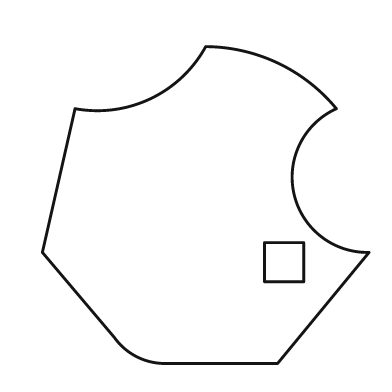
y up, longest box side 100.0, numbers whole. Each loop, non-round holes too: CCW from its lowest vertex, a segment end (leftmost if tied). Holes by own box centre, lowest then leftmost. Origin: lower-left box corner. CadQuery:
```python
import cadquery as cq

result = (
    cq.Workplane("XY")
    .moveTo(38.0, 0.0)
    .lineTo(72.0, 0.0)
    .lineTo(100.0, 34.0)
    .threePointArc((77.0, 52.0), (90.0, 78.0))
    .threePointArc((72.0, 92.0), (50.0, 97.0))
    .threePointArc((33.0, 81.0), (10.0, 78.0))
    .lineTo(0.0, 34.0)
    .lineTo(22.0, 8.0)
    .threePointArc((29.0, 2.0), (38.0, 0.0))
    .close()
    .moveTo(68.0, 25.0)
    .lineTo(80.0, 25.0)
    .lineTo(80.0, 37.0)
    .lineTo(68.0, 37.0)
    .close()
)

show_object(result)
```